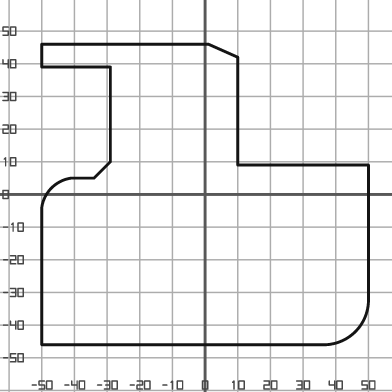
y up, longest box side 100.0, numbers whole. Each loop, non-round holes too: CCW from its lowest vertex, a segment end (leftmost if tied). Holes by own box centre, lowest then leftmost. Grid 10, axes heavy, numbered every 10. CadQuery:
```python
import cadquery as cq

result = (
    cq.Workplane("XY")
    .moveTo(-50.0, -46.0)
    .lineTo(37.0, -46.0)
    .threePointArc((46.0, -42.0), (50.0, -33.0))
    .lineTo(50.0, 9.0)
    .lineTo(10.0, 9.0)
    .lineTo(10.0, 42.0)
    .lineTo(1.0, 46.0)
    .lineTo(-50.0, 46.0)
    .lineTo(-50.0, 39.0)
    .lineTo(-29.0, 39.0)
    .lineTo(-29.0, 10.0)
    .lineTo(-34.0, 5.0)
    .lineTo(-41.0, 5.0)
    .threePointArc((-47.0, 2.0), (-50.0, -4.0))
    .close()
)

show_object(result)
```